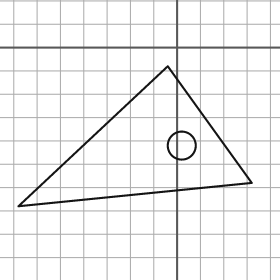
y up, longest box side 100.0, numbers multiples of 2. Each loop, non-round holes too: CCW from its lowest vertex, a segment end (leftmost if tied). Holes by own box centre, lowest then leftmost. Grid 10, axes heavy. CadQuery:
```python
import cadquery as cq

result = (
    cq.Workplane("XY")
    .moveTo(-68.0, -68.0)
    .lineTo(32.0, -58.0)
    .lineTo(-4.0, -8.0)
    .close()
    .moveTo(2.0, -42.0)
    .circle(6.0)
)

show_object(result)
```